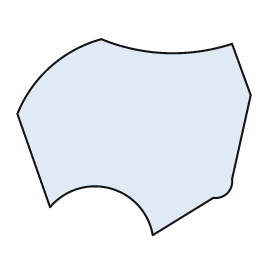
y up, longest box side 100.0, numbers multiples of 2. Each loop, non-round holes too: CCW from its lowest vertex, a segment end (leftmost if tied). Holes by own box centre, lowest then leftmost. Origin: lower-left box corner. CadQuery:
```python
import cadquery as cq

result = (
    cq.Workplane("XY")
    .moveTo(58.0, 0.0)
    .lineTo(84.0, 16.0)
    .threePointArc((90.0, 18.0), (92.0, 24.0))
    .lineTo(100.0, 60.0)
    .lineTo(92.0, 82.0)
    .threePointArc((64.0, 78.0), (36.0, 84.0))
    .threePointArc((14.0, 72.0), (0.0, 52.0))
    .lineTo(14.0, 12.0)
    .threePointArc((40.0, 20.0), (58.0, 0.0))
    .close()
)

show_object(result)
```